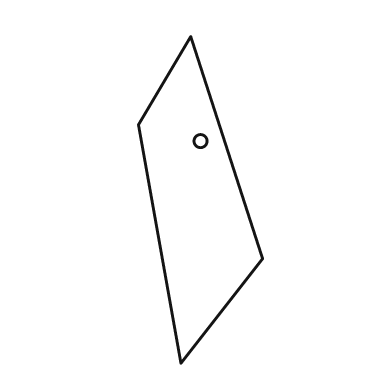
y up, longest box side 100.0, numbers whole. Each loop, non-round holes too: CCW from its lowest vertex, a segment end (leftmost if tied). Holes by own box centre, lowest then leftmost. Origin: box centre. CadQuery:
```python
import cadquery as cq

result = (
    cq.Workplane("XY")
    .moveTo(-6.0, -50.0)
    .lineTo(19.0, -18.0)
    .lineTo(-3.0, 50.0)
    .lineTo(-19.0, 23.0)
    .close()
    .moveTo(0.0, 18.0)
    .circle(2.0)
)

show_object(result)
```